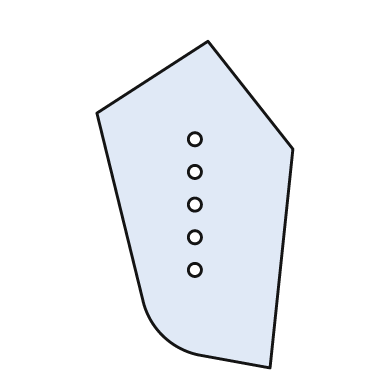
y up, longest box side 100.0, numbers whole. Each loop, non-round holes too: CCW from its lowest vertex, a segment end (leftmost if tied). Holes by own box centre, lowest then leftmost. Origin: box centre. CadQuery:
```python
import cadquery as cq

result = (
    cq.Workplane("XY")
    .moveTo(23.0, -50.0)
    .lineTo(30.0, 17.0)
    .lineTo(4.0, 50.0)
    .lineTo(-30.0, 28.0)
    .lineTo(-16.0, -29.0)
    .threePointArc((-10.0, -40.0), (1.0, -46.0))
    .close()
    .moveTo(0.0, -20.0)
    .circle(2.0)
    .moveTo(0.0, -10.0)
    .circle(2.0)
    .moveTo(0.0, 0.0)
    .circle(2.0)
    .moveTo(0.0, 10.0)
    .circle(2.0)
    .moveTo(0.0, 20.0)
    .circle(2.0)
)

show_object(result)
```